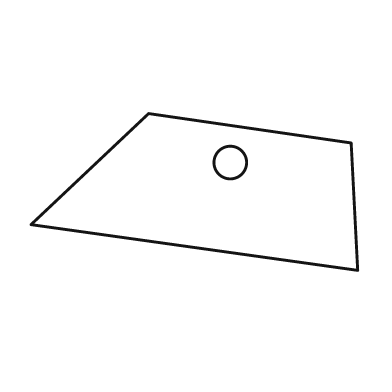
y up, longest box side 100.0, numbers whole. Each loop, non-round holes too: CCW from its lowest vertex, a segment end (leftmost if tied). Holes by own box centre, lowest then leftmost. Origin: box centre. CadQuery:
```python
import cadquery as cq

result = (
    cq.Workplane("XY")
    .moveTo(50.0, -24.0)
    .lineTo(48.0, 15.0)
    .lineTo(-14.0, 24.0)
    .lineTo(-50.0, -10.0)
    .close()
    .moveTo(11.0, 9.0)
    .circle(5.0)
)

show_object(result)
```